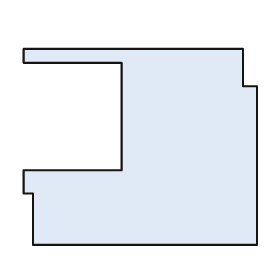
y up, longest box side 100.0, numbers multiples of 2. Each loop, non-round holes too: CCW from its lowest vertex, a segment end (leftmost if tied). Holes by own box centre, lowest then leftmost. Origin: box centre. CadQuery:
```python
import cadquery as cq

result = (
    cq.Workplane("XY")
    .moveTo(-46.0, -42.0)
    .lineTo(50.0, -42.0)
    .lineTo(50.0, 26.0)
    .lineTo(44.0, 26.0)
    .lineTo(44.0, 42.0)
    .lineTo(-50.0, 42.0)
    .lineTo(-50.0, 36.0)
    .lineTo(-8.0, 36.0)
    .lineTo(-8.0, -10.0)
    .lineTo(-50.0, -10.0)
    .lineTo(-50.0, -20.0)
    .lineTo(-46.0, -20.0)
    .close()
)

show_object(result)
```